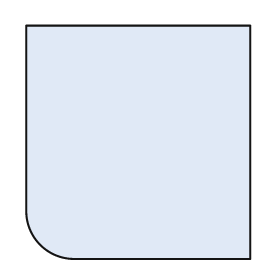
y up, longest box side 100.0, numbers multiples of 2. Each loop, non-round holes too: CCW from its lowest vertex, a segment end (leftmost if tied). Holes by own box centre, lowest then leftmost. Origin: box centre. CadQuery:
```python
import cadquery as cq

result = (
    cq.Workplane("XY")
    .moveTo(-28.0, -50.0)
    .lineTo(48.0, -50.0)
    .lineTo(48.0, 50.0)
    .lineTo(-48.0, 50.0)
    .lineTo(-48.0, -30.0)
    .threePointArc((-42.0, -44.0), (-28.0, -50.0))
    .close()
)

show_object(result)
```